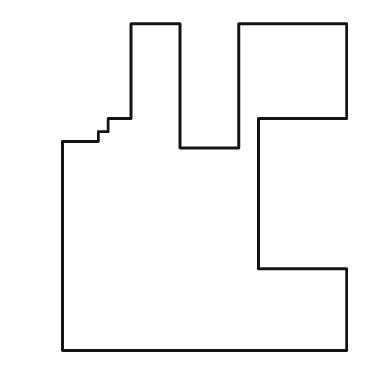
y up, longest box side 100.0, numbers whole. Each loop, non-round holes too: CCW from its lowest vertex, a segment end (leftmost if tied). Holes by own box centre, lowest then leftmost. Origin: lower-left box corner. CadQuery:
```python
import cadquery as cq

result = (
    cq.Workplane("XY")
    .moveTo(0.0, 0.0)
    .lineTo(87.0, 0.0)
    .lineTo(87.0, 25.0)
    .lineTo(60.0, 25.0)
    .lineTo(60.0, 71.0)
    .lineTo(87.0, 71.0)
    .lineTo(87.0, 100.0)
    .lineTo(54.0, 100.0)
    .lineTo(54.0, 62.0)
    .lineTo(36.0, 62.0)
    .lineTo(36.0, 100.0)
    .lineTo(21.0, 100.0)
    .lineTo(21.0, 71.0)
    .lineTo(14.0, 71.0)
    .lineTo(14.0, 67.0)
    .lineTo(11.0, 67.0)
    .lineTo(11.0, 64.0)
    .lineTo(0.0, 64.0)
    .close()
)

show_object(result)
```